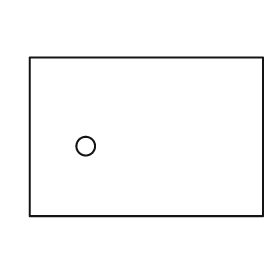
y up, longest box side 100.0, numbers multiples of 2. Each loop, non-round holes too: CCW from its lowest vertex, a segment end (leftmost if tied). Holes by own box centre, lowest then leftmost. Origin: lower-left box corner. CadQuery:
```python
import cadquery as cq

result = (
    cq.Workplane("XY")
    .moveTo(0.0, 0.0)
    .lineTo(100.0, 0.0)
    .lineTo(100.0, 68.0)
    .lineTo(0.0, 68.0)
    .close()
    .moveTo(24.0, 30.0)
    .circle(4.0)
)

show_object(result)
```